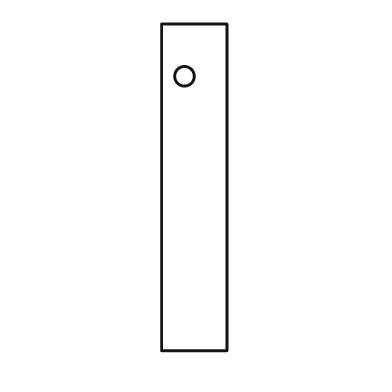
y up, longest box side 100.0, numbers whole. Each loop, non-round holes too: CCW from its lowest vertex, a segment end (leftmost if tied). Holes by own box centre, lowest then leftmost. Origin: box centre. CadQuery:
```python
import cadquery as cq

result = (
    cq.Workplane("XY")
    .moveTo(-10.0, -50.0)
    .lineTo(10.0, -50.0)
    .lineTo(10.0, 50.0)
    .lineTo(-10.0, 50.0)
    .close()
    .moveTo(-3.0, 34.0)
    .circle(3.0)
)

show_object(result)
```